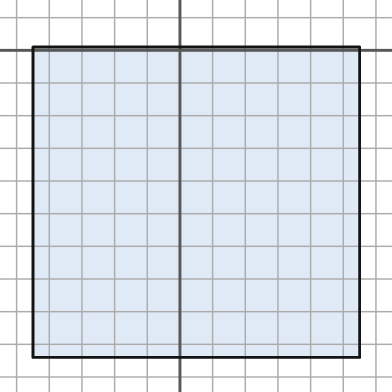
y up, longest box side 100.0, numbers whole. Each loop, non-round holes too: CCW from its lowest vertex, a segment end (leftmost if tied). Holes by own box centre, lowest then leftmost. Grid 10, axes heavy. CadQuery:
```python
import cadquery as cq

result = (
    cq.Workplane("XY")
    .moveTo(-45.0, -94.0)
    .lineTo(55.0, -94.0)
    .lineTo(55.0, 1.0)
    .lineTo(-45.0, 1.0)
    .close()
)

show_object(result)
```